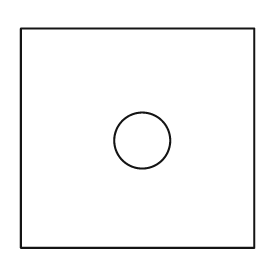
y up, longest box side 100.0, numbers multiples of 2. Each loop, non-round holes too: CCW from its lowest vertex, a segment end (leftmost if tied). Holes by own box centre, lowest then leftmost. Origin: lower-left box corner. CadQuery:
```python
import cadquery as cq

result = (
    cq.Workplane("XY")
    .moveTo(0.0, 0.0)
    .lineTo(100.0, 0.0)
    .lineTo(100.0, 94.0)
    .lineTo(0.0, 94.0)
    .close()
    .moveTo(52.0, 46.0)
    .circle(12.0)
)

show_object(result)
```